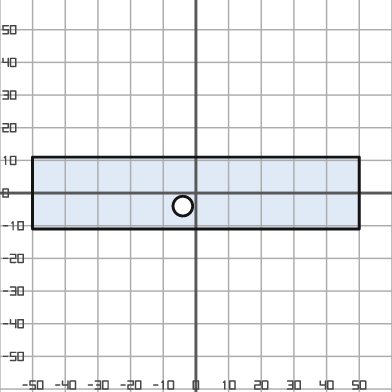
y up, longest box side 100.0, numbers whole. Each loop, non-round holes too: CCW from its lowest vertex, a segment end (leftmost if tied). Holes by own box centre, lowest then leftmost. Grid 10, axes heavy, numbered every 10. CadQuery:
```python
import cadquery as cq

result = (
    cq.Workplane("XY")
    .moveTo(-50.0, -11.0)
    .lineTo(50.0, -11.0)
    .lineTo(50.0, 11.0)
    .lineTo(-50.0, 11.0)
    .close()
    .moveTo(-4.0, -4.0)
    .circle(3.0)
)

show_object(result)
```